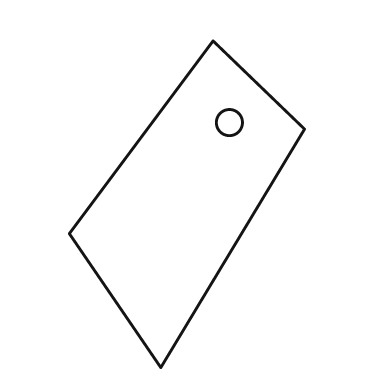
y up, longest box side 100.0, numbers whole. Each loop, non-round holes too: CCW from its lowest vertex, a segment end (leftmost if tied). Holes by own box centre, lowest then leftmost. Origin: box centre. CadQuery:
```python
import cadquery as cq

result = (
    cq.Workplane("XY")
    .moveTo(-8.0, -50.0)
    .lineTo(36.0, 23.0)
    .lineTo(8.0, 50.0)
    .lineTo(-36.0, -9.0)
    .close()
    .moveTo(13.0, 25.0)
    .circle(4.0)
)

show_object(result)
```